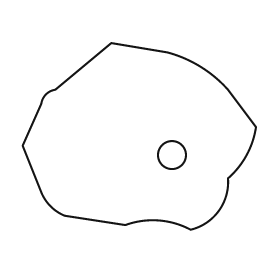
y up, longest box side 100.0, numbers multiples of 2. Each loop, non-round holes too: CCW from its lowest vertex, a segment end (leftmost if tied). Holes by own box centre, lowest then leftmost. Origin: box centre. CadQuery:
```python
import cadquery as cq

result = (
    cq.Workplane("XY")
    .moveTo(22.0, -40.0)
    .threePointArc((34.0, -32.0), (38.0, -18.0))
    .threePointArc((46.0, -8.0), (50.0, 4.0))
    .lineTo(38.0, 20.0)
    .threePointArc((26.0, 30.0), (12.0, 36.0))
    .lineTo(-12.0, 40.0)
    .lineTo(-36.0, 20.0)
    .threePointArc((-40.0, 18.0), (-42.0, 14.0))
    .lineTo(-50.0, -4.0)
    .lineTo(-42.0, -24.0)
    .threePointArc((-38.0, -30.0), (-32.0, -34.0))
    .lineTo(-6.0, -38.0)
    .threePointArc((8.0, -36.0), (22.0, -40.0))
    .close()
    .moveTo(14.0, -8.0)
    .circle(6.0)
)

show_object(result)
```